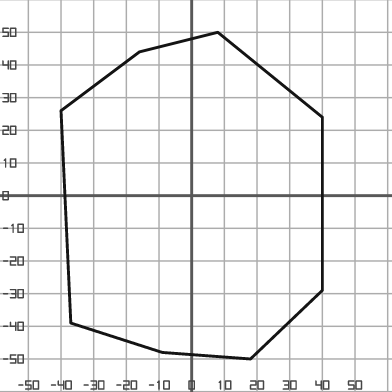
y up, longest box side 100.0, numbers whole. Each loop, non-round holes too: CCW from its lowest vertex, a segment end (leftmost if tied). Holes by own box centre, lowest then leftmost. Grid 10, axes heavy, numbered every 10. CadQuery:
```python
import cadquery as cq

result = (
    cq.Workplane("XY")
    .moveTo(18.0, -50.0)
    .lineTo(40.0, -29.0)
    .lineTo(40.0, 24.0)
    .lineTo(8.0, 50.0)
    .lineTo(-16.0, 44.0)
    .lineTo(-40.0, 26.0)
    .lineTo(-37.0, -39.0)
    .lineTo(-9.0, -48.0)
    .close()
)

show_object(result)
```